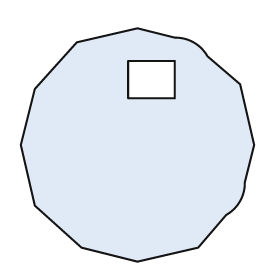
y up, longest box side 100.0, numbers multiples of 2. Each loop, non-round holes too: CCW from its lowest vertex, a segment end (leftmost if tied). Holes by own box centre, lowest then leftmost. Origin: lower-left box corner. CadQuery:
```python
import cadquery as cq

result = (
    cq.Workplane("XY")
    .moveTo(50.0, 0.0)
    .lineTo(76.0, 6.0)
    .lineTo(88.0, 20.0)
    .threePointArc((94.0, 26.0), (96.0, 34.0))
    .lineTo(100.0, 50.0)
    .lineTo(94.0, 76.0)
    .lineTo(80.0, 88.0)
    .threePointArc((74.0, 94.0), (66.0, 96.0))
    .lineTo(50.0, 100.0)
    .lineTo(24.0, 94.0)
    .lineTo(6.0, 74.0)
    .lineTo(0.0, 50.0)
    .lineTo(6.0, 24.0)
    .lineTo(26.0, 6.0)
    .close()
    .moveTo(46.0, 70.0)
    .lineTo(66.0, 70.0)
    .lineTo(66.0, 86.0)
    .lineTo(46.0, 86.0)
    .close()
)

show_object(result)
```